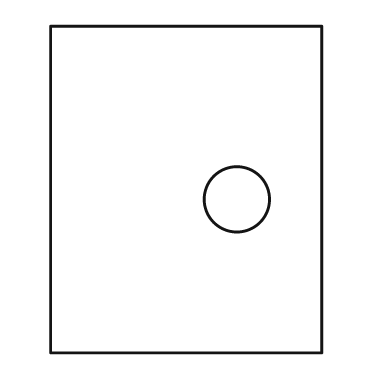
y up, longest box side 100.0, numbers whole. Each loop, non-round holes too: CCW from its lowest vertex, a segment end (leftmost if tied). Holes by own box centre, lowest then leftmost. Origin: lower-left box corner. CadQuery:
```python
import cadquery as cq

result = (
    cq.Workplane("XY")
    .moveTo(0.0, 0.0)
    .lineTo(83.0, 0.0)
    .lineTo(83.0, 100.0)
    .lineTo(0.0, 100.0)
    .close()
    .moveTo(57.0, 47.0)
    .circle(10.0)
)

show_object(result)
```